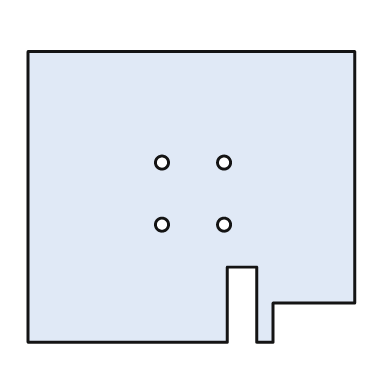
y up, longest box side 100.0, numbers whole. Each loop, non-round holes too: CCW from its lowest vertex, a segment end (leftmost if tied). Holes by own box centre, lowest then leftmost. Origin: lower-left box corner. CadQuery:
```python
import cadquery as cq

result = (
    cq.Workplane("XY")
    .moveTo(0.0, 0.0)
    .lineTo(61.0, 0.0)
    .lineTo(61.0, 23.0)
    .lineTo(70.0, 23.0)
    .lineTo(70.0, 0.0)
    .lineTo(75.0, 0.0)
    .lineTo(75.0, 12.0)
    .lineTo(100.0, 12.0)
    .lineTo(100.0, 89.0)
    .lineTo(0.0, 89.0)
    .close()
    .moveTo(41.0, 36.0)
    .circle(2.0)
    .moveTo(60.0, 36.0)
    .circle(2.0)
    .moveTo(41.0, 55.0)
    .circle(2.0)
    .moveTo(60.0, 55.0)
    .circle(2.0)
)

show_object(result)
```